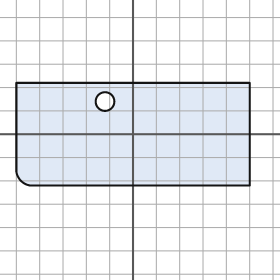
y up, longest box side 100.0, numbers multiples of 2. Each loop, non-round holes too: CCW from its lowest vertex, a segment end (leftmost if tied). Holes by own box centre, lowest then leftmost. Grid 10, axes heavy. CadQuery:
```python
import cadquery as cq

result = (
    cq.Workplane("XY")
    .moveTo(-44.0, -22.0)
    .lineTo(50.0, -22.0)
    .lineTo(50.0, 22.0)
    .lineTo(-50.0, 22.0)
    .lineTo(-50.0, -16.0)
    .threePointArc((-48.0, -20.0), (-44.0, -22.0))
    .close()
    .moveTo(-12.0, 14.0)
    .circle(4.0)
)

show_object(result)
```